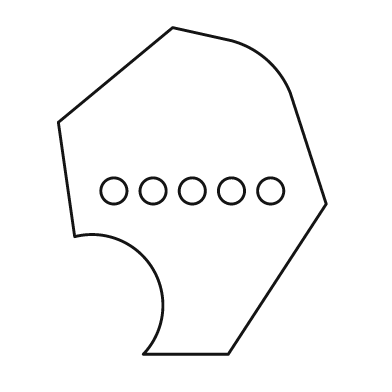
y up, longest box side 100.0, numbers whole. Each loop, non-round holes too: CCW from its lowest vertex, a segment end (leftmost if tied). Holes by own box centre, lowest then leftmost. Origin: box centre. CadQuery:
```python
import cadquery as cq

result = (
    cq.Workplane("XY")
    .moveTo(-15.0, -50.0)
    .lineTo(11.0, -50.0)
    .lineTo(41.0, -4.0)
    .lineTo(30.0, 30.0)
    .threePointArc((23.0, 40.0), (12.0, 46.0))
    .lineTo(-6.0, 50.0)
    .lineTo(-41.0, 21.0)
    .lineTo(-36.0, -14.0)
    .threePointArc((-12.0, -24.0), (-15.0, -50.0))
    .close()
    .moveTo(-24.0, 0.0)
    .circle(4.0)
    .moveTo(-12.0, 0.0)
    .circle(4.0)
    .moveTo(0.0, 0.0)
    .circle(4.0)
    .moveTo(12.0, 0.0)
    .circle(4.0)
    .moveTo(24.0, 0.0)
    .circle(4.0)
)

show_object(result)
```